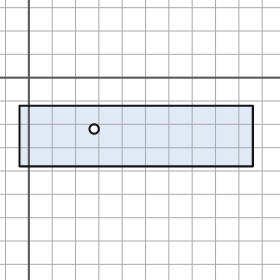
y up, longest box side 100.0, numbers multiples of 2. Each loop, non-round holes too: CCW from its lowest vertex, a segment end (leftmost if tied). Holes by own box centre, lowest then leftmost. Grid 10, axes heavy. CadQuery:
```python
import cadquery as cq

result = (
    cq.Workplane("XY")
    .moveTo(-4.0, -38.0)
    .lineTo(96.0, -38.0)
    .lineTo(96.0, -12.0)
    .lineTo(-4.0, -12.0)
    .close()
    .moveTo(28.0, -22.0)
    .circle(2.0)
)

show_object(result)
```